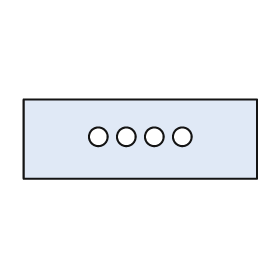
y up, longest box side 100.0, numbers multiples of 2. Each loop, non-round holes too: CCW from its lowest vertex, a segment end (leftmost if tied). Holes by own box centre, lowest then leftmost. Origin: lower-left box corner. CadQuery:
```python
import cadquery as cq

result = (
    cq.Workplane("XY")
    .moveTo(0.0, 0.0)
    .lineTo(100.0, 0.0)
    .lineTo(100.0, 34.0)
    .lineTo(0.0, 34.0)
    .close()
    .moveTo(32.0, 18.0)
    .circle(4.0)
    .moveTo(44.0, 18.0)
    .circle(4.0)
    .moveTo(56.0, 18.0)
    .circle(4.0)
    .moveTo(68.0, 18.0)
    .circle(4.0)
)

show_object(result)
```